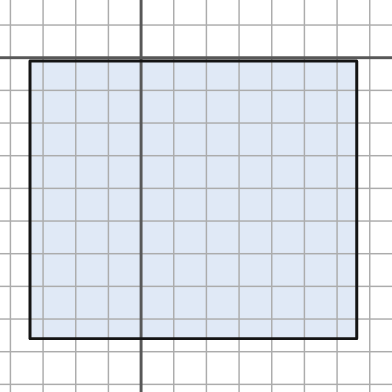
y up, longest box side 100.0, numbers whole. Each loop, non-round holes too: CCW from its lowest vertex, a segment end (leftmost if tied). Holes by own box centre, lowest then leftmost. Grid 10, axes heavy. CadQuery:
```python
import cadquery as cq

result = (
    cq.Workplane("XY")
    .moveTo(-34.0, -86.0)
    .lineTo(66.0, -86.0)
    .lineTo(66.0, -1.0)
    .lineTo(-34.0, -1.0)
    .close()
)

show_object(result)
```